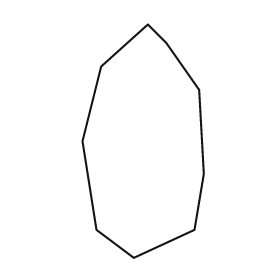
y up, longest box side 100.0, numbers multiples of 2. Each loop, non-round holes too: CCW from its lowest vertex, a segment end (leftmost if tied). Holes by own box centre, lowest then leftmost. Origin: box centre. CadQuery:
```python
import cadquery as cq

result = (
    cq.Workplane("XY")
    .moveTo(-4.0, -50.0)
    .lineTo(22.0, -38.0)
    .lineTo(26.0, -14.0)
    .lineTo(24.0, 22.0)
    .lineTo(10.0, 42.0)
    .lineTo(2.0, 50.0)
    .lineTo(-18.0, 32.0)
    .lineTo(-26.0, 0.0)
    .lineTo(-20.0, -38.0)
    .close()
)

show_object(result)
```